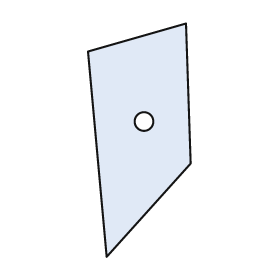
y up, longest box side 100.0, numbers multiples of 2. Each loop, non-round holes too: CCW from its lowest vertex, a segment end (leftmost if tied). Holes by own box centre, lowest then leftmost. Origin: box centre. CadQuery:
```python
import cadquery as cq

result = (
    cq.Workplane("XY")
    .moveTo(-14.0, -50.0)
    .lineTo(22.0, -10.0)
    .lineTo(20.0, 50.0)
    .lineTo(-22.0, 38.0)
    .close()
    .moveTo(2.0, 8.0)
    .circle(4.0)
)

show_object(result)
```